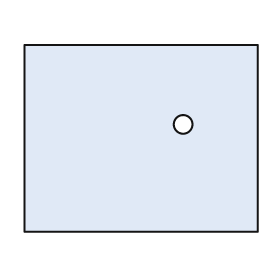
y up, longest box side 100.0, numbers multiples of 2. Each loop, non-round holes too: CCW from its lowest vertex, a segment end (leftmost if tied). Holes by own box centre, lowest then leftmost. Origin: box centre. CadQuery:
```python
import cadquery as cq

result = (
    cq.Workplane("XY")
    .moveTo(-50.0, -40.0)
    .lineTo(50.0, -40.0)
    .lineTo(50.0, 40.0)
    .lineTo(-50.0, 40.0)
    .close()
    .moveTo(18.0, 6.0)
    .circle(4.0)
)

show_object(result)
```